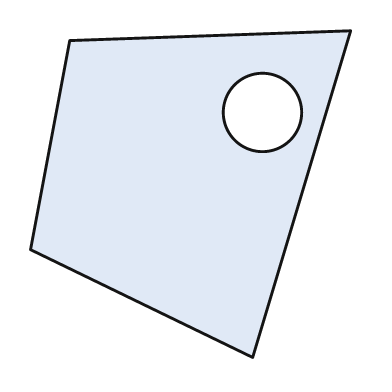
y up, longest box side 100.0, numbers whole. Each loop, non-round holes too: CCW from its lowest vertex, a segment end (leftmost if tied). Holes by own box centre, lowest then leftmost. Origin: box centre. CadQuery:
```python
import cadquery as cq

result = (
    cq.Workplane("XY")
    .moveTo(19.0, -50.0)
    .lineTo(49.0, 50.0)
    .lineTo(-37.0, 47.0)
    .lineTo(-49.0, -17.0)
    .close()
    .moveTo(22.0, 25.0)
    .circle(12.0)
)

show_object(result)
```